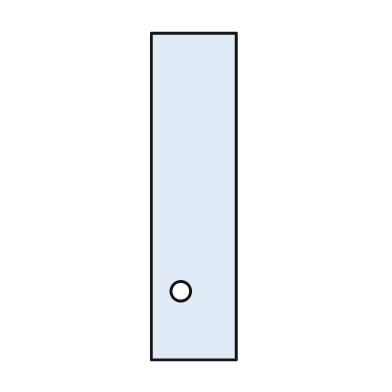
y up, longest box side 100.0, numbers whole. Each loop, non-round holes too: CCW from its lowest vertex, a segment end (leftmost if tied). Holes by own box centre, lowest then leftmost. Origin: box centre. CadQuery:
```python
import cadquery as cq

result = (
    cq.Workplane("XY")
    .moveTo(-13.0, -50.0)
    .lineTo(13.0, -50.0)
    .lineTo(13.0, 50.0)
    .lineTo(-13.0, 50.0)
    .close()
    .moveTo(-4.0, -29.0)
    .circle(3.0)
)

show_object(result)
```